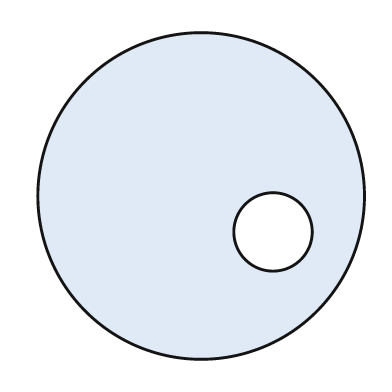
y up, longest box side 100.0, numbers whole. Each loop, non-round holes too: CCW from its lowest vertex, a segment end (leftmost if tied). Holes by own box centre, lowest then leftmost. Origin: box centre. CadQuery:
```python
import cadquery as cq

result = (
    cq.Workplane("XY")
    .moveTo(0.0, 0.0)
    .circle(50.0)
    .moveTo(22.0, -11.0)
    .circle(12.0)
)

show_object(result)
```